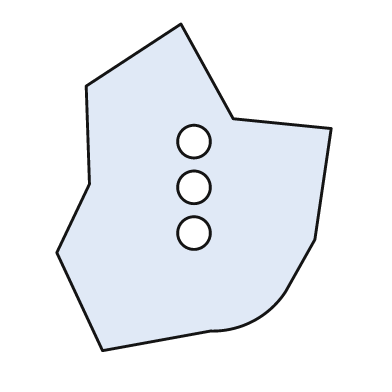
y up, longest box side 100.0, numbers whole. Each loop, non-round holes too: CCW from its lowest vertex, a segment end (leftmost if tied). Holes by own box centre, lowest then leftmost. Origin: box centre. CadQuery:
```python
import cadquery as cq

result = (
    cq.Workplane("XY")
    .moveTo(-28.0, -50.0)
    .lineTo(5.0, -44.0)
    .threePointArc((18.0, -41.0), (28.0, -32.0))
    .lineTo(37.0, -16.0)
    .lineTo(42.0, 18.0)
    .lineTo(12.0, 21.0)
    .lineTo(-4.0, 50.0)
    .lineTo(-33.0, 31.0)
    .lineTo(-32.0, 1.0)
    .lineTo(-42.0, -20.0)
    .close()
    .moveTo(0.0, -14.0)
    .circle(5.0)
    .moveTo(0.0, 0.0)
    .circle(5.0)
    .moveTo(0.0, 14.0)
    .circle(5.0)
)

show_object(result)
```